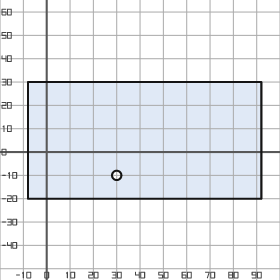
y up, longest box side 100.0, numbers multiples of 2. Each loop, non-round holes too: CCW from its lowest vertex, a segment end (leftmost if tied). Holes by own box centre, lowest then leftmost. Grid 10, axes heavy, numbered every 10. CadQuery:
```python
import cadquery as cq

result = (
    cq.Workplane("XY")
    .moveTo(-8.0, -20.0)
    .lineTo(92.0, -20.0)
    .lineTo(92.0, 30.0)
    .lineTo(-8.0, 30.0)
    .close()
    .moveTo(30.0, -10.0)
    .circle(2.0)
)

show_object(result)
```